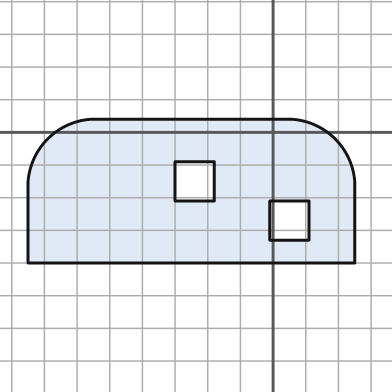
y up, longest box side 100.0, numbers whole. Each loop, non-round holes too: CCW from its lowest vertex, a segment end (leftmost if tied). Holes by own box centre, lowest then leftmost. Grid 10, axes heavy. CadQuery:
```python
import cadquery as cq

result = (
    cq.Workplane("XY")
    .moveTo(-75.0, -40.0)
    .lineTo(25.0, -40.0)
    .lineTo(25.0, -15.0)
    .threePointArc((19.0, -2.0), (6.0, 4.0))
    .lineTo(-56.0, 4.0)
    .threePointArc((-69.0, -2.0), (-75.0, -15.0))
    .close()
    .moveTo(-1.0, -33.0)
    .lineTo(11.0, -33.0)
    .lineTo(11.0, -21.0)
    .lineTo(-1.0, -21.0)
    .close()
    .moveTo(-30.0, -21.0)
    .lineTo(-18.0, -21.0)
    .lineTo(-18.0, -9.0)
    .lineTo(-30.0, -9.0)
    .close()
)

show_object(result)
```